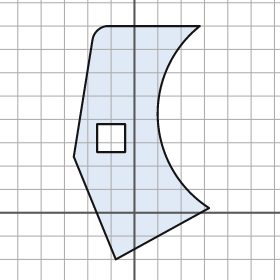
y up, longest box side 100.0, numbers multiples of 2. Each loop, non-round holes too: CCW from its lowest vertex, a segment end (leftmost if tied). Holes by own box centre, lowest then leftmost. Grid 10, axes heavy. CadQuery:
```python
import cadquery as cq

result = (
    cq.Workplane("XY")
    .moveTo(-8.0, -20.0)
    .lineTo(32.0, 2.0)
    .threePointArc((10.0, 40.0), (28.0, 80.0))
    .lineTo(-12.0, 80.0)
    .threePointArc((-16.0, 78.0), (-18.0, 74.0))
    .lineTo(-26.0, 24.0)
    .close()
    .moveTo(-16.0, 26.0)
    .lineTo(-4.0, 26.0)
    .lineTo(-4.0, 38.0)
    .lineTo(-16.0, 38.0)
    .close()
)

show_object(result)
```